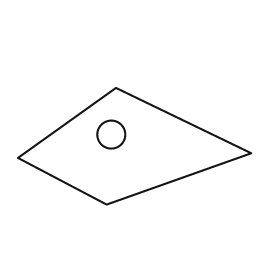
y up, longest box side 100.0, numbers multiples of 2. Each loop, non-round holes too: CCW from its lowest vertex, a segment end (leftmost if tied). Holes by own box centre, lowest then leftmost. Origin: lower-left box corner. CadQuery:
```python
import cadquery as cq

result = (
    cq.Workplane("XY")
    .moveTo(38.0, 0.0)
    .lineTo(100.0, 22.0)
    .lineTo(42.0, 50.0)
    .lineTo(0.0, 20.0)
    .close()
    .moveTo(40.0, 30.0)
    .circle(6.0)
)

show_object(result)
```